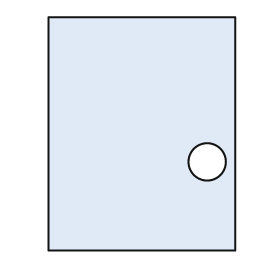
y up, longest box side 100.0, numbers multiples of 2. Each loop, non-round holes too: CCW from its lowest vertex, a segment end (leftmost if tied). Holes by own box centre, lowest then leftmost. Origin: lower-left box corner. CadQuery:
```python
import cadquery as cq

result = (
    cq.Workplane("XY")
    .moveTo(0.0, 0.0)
    .lineTo(80.0, 0.0)
    .lineTo(80.0, 100.0)
    .lineTo(0.0, 100.0)
    .close()
    .moveTo(68.0, 38.0)
    .circle(8.0)
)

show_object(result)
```